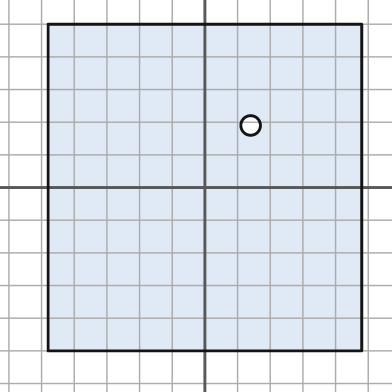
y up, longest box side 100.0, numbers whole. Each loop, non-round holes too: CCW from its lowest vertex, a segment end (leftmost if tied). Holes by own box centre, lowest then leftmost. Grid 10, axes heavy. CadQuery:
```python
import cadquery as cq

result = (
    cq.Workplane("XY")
    .moveTo(-48.0, -50.0)
    .lineTo(48.0, -50.0)
    .lineTo(48.0, 50.0)
    .lineTo(-48.0, 50.0)
    .close()
    .moveTo(14.0, 19.0)
    .circle(3.0)
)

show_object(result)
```